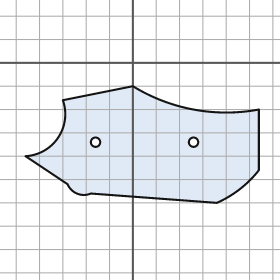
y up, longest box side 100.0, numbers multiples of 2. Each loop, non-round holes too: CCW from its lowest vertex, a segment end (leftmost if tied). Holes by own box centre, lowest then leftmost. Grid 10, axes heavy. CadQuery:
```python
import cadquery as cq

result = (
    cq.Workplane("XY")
    .moveTo(36.0, -60.0)
    .threePointArc((46.0, -54.0), (54.0, -46.0))
    .lineTo(54.0, -20.0)
    .threePointArc((26.0, -20.0), (0.0, -10.0))
    .lineTo(-30.0, -16.0)
    .threePointArc((-32.0, -32.0), (-46.0, -40.0))
    .lineTo(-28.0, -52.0)
    .threePointArc((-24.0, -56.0), (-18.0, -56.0))
    .close()
    .moveTo(-16.0, -34.0)
    .circle(2.0)
    .moveTo(26.0, -34.0)
    .circle(2.0)
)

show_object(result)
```